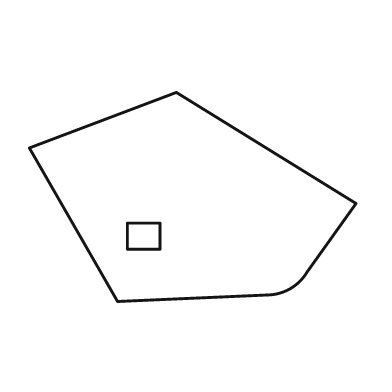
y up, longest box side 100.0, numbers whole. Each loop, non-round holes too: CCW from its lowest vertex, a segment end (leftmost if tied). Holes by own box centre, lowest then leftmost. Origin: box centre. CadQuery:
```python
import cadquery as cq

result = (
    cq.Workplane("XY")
    .moveTo(-23.0, -32.0)
    .lineTo(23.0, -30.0)
    .threePointArc((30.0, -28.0), (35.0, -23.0))
    .lineTo(50.0, -2.0)
    .lineTo(-5.0, 32.0)
    .lineTo(-50.0, 15.0)
    .close()
    .moveTo(-20.0, -16.0)
    .lineTo(-10.0, -16.0)
    .lineTo(-10.0, -8.0)
    .lineTo(-20.0, -8.0)
    .close()
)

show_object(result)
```